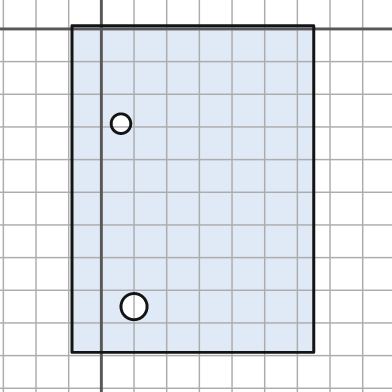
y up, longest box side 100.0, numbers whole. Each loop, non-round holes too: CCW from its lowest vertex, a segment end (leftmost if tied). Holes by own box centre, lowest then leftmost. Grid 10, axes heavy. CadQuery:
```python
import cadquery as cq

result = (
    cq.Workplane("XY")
    .moveTo(-9.0, -99.0)
    .lineTo(65.0, -99.0)
    .lineTo(65.0, 1.0)
    .lineTo(-9.0, 1.0)
    .close()
    .moveTo(10.0, -85.0)
    .circle(4.0)
    .moveTo(6.0, -29.0)
    .circle(3.0)
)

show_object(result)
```